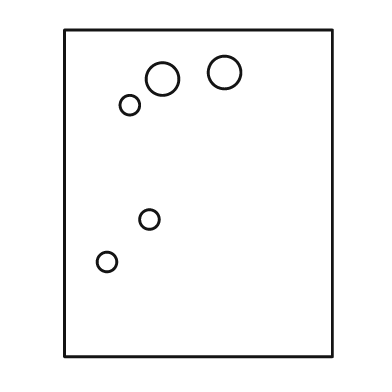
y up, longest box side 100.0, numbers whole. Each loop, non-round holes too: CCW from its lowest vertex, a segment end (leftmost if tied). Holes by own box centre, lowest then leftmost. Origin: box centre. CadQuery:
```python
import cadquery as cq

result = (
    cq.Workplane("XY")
    .moveTo(-41.0, -50.0)
    .lineTo(41.0, -50.0)
    .lineTo(41.0, 50.0)
    .lineTo(-41.0, 50.0)
    .close()
    .moveTo(-28.0, -21.0)
    .circle(3.0)
    .moveTo(-15.0, -8.0)
    .circle(3.0)
    .moveTo(-21.0, 27.0)
    .circle(3.0)
    .moveTo(-11.0, 35.0)
    .circle(5.0)
    .moveTo(8.0, 37.0)
    .circle(5.0)
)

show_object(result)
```